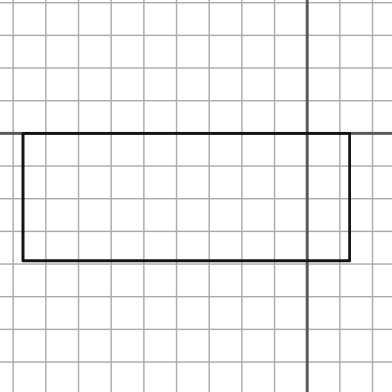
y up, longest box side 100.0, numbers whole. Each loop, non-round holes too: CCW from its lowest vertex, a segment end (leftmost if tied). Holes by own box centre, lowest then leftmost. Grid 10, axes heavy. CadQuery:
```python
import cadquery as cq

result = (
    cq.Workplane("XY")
    .moveTo(-87.0, -39.0)
    .lineTo(13.0, -39.0)
    .lineTo(13.0, 0.0)
    .lineTo(-87.0, 0.0)
    .close()
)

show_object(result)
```